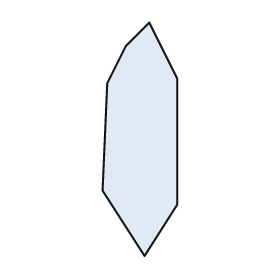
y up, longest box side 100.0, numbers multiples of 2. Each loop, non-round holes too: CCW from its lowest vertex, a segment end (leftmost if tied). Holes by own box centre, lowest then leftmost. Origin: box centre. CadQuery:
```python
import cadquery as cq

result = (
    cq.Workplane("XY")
    .moveTo(2.0, -50.0)
    .lineTo(16.0, -28.0)
    .lineTo(16.0, 26.0)
    .lineTo(4.0, 50.0)
    .lineTo(-6.0, 40.0)
    .lineTo(-14.0, 24.0)
    .lineTo(-16.0, -22.0)
    .close()
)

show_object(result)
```